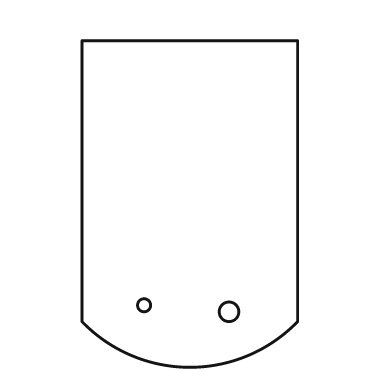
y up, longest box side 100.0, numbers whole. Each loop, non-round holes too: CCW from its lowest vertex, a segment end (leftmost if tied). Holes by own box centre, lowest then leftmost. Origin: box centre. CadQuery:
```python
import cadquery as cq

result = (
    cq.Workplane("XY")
    .moveTo(-33.0, -36.0)
    .threePointArc((0.0, -50.0), (33.0, -36.0))
    .lineTo(33.0, 50.0)
    .lineTo(-33.0, 50.0)
    .close()
    .moveTo(12.0, -33.0)
    .circle(3.0)
    .moveTo(-14.0, -31.0)
    .circle(2.0)
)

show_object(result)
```